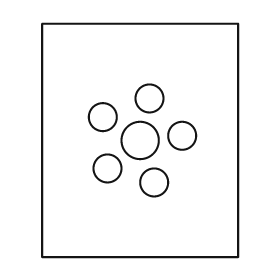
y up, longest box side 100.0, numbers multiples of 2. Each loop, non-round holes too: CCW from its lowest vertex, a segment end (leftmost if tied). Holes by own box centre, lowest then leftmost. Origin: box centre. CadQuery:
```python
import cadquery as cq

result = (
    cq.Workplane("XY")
    .moveTo(-42.0, -50.0)
    .lineTo(42.0, -50.0)
    .lineTo(42.0, 50.0)
    .lineTo(-42.0, 50.0)
    .close()
    .moveTo(6.0, -18.0)
    .circle(6.0)
    .moveTo(-14.0, -12.0)
    .circle(6.0)
    .moveTo(0.0, 0.0)
    .circle(8.0)
    .moveTo(18.0, 2.0)
    .circle(6.0)
    .moveTo(-16.0, 10.0)
    .circle(6.0)
    .moveTo(4.0, 18.0)
    .circle(6.0)
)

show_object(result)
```